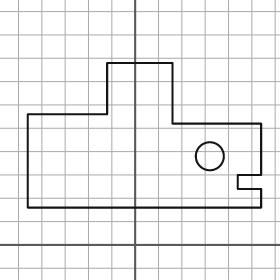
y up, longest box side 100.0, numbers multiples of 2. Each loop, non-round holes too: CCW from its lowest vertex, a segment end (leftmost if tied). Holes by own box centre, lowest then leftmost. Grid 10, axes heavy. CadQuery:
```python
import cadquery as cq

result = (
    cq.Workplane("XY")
    .moveTo(-46.0, 16.0)
    .lineTo(54.0, 16.0)
    .lineTo(54.0, 24.0)
    .lineTo(44.0, 24.0)
    .lineTo(44.0, 30.0)
    .lineTo(54.0, 30.0)
    .lineTo(54.0, 52.0)
    .lineTo(16.0, 52.0)
    .lineTo(16.0, 78.0)
    .lineTo(-12.0, 78.0)
    .lineTo(-12.0, 56.0)
    .lineTo(-46.0, 56.0)
    .close()
    .moveTo(32.0, 38.0)
    .circle(6.0)
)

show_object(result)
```